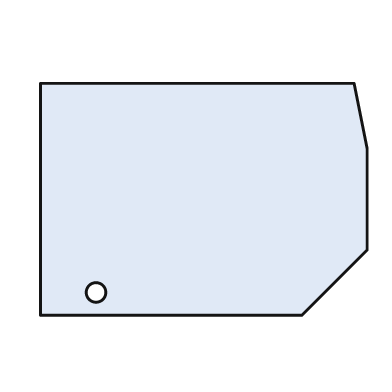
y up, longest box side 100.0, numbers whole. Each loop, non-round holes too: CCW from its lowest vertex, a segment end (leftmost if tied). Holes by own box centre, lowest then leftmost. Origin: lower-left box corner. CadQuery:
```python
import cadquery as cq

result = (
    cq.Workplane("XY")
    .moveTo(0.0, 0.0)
    .lineTo(80.0, 0.0)
    .lineTo(100.0, 20.0)
    .lineTo(100.0, 51.0)
    .lineTo(96.0, 71.0)
    .lineTo(0.0, 71.0)
    .close()
    .moveTo(17.0, 7.0)
    .circle(3.0)
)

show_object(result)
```